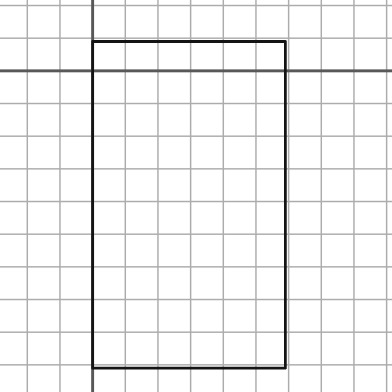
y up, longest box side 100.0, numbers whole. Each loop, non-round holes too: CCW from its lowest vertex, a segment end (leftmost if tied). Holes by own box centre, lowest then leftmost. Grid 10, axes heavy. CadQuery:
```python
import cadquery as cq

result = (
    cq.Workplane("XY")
    .moveTo(0.0, -91.0)
    .lineTo(59.0, -91.0)
    .lineTo(59.0, 9.0)
    .lineTo(0.0, 9.0)
    .close()
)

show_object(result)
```